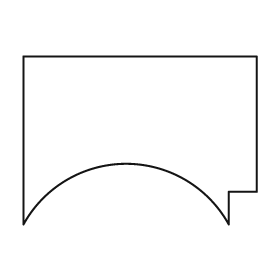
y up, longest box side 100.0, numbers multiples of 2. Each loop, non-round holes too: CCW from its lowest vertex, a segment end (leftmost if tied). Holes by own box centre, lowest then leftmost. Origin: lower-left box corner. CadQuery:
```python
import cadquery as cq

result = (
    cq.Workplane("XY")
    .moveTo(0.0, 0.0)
    .threePointArc((44.0, 26.0), (88.0, 0.0))
    .lineTo(88.0, 14.0)
    .lineTo(100.0, 14.0)
    .lineTo(100.0, 72.0)
    .lineTo(0.0, 72.0)
    .close()
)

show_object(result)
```